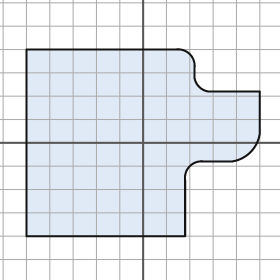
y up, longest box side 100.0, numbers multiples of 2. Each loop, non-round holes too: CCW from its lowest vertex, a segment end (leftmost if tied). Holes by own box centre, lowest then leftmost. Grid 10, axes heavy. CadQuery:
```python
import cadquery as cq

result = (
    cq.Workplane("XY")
    .moveTo(-50.0, -40.0)
    .lineTo(18.0, -40.0)
    .lineTo(18.0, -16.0)
    .threePointArc((20.0, -10.0), (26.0, -8.0))
    .lineTo(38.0, -8.0)
    .threePointArc((46.0, -4.0), (50.0, 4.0))
    .lineTo(50.0, 22.0)
    .lineTo(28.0, 22.0)
    .threePointArc((24.0, 24.0), (22.0, 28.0))
    .lineTo(22.0, 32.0)
    .threePointArc((20.0, 38.0), (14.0, 40.0))
    .lineTo(-50.0, 40.0)
    .close()
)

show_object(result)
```